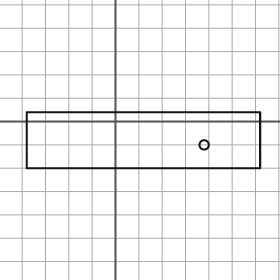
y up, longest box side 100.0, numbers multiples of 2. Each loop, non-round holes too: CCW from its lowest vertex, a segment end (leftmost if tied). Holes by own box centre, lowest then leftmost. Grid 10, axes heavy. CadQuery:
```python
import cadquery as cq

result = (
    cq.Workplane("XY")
    .moveTo(-38.0, -20.0)
    .lineTo(62.0, -20.0)
    .lineTo(62.0, 4.0)
    .lineTo(-38.0, 4.0)
    .close()
    .moveTo(38.0, -10.0)
    .circle(2.0)
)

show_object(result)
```